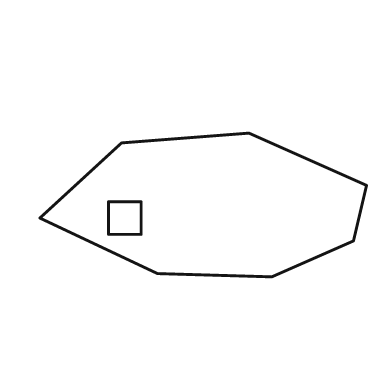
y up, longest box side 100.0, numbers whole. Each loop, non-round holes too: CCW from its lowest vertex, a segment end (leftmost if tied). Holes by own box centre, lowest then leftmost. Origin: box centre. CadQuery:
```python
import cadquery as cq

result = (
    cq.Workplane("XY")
    .moveTo(21.0, -22.0)
    .lineTo(46.0, -11.0)
    .lineTo(50.0, 6.0)
    .lineTo(14.0, 22.0)
    .lineTo(-25.0, 19.0)
    .lineTo(-50.0, -4.0)
    .lineTo(-14.0, -21.0)
    .close()
    .moveTo(-29.0, -9.0)
    .lineTo(-19.0, -9.0)
    .lineTo(-19.0, 1.0)
    .lineTo(-29.0, 1.0)
    .close()
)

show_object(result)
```